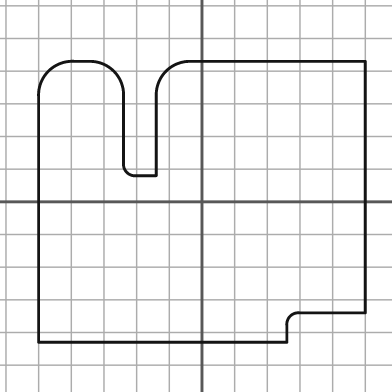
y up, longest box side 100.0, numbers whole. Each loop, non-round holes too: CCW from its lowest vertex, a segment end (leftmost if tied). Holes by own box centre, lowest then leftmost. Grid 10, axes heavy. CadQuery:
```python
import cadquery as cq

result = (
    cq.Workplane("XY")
    .moveTo(-50.0, -43.0)
    .lineTo(26.0, -43.0)
    .lineTo(26.0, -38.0)
    .threePointArc((27.0, -35.0), (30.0, -34.0))
    .lineTo(50.0, -34.0)
    .lineTo(50.0, 43.0)
    .lineTo(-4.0, 43.0)
    .threePointArc((-11.0, 40.0), (-14.0, 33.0))
    .lineTo(-14.0, 8.0)
    .lineTo(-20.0, 8.0)
    .threePointArc((-23.0, 9.0), (-24.0, 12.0))
    .lineTo(-24.0, 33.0)
    .threePointArc((-27.0, 40.0), (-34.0, 43.0))
    .lineTo(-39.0, 43.0)
    .threePointArc((-47.0, 40.0), (-50.0, 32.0))
    .close()
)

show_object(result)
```